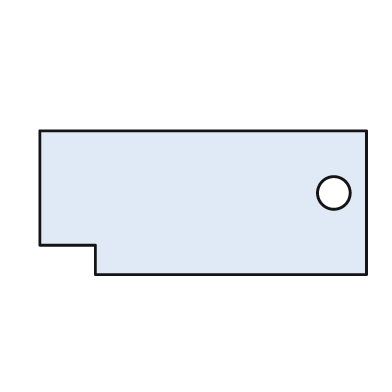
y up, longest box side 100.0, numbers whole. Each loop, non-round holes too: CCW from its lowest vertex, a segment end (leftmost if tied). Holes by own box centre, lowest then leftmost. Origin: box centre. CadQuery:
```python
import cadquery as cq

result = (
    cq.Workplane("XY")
    .moveTo(-33.0, -22.0)
    .lineTo(50.0, -22.0)
    .lineTo(50.0, 22.0)
    .lineTo(-50.0, 22.0)
    .lineTo(-50.0, -13.0)
    .lineTo(-33.0, -13.0)
    .close()
    .moveTo(40.0, 3.0)
    .circle(5.0)
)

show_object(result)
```